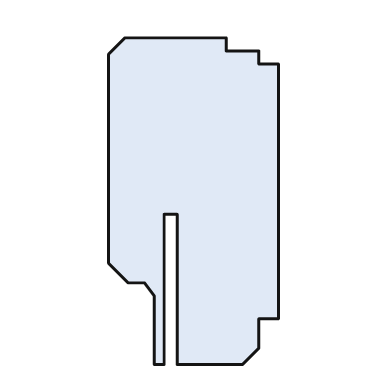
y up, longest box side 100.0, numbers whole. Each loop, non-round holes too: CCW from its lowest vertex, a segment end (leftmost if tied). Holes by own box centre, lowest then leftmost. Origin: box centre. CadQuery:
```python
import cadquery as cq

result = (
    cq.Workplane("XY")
    .moveTo(-12.0, -50.0)
    .lineTo(-9.0, -50.0)
    .lineTo(-9.0, -4.0)
    .lineTo(-5.0, -4.0)
    .lineTo(-5.0, -50.0)
    .lineTo(15.0, -50.0)
    .lineTo(20.0, -45.0)
    .lineTo(20.0, -36.0)
    .lineTo(26.0, -36.0)
    .lineTo(26.0, 42.0)
    .lineTo(20.0, 42.0)
    .lineTo(20.0, 46.0)
    .lineTo(10.0, 46.0)
    .lineTo(10.0, 50.0)
    .lineTo(-21.0, 50.0)
    .lineTo(-26.0, 45.0)
    .lineTo(-26.0, -19.0)
    .lineTo(-20.0, -25.0)
    .lineTo(-15.0, -25.0)
    .lineTo(-12.0, -29.0)
    .close()
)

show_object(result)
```